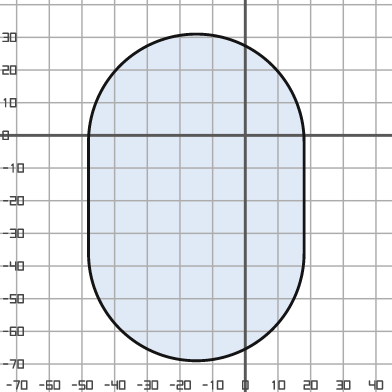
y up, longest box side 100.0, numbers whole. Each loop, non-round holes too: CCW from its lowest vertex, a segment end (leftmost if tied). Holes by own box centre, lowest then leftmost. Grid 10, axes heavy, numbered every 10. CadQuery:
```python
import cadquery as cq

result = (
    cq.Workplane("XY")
    .moveTo(-48.0, -36.0)
    .threePointArc((-15.0, -69.0), (18.0, -36.0))
    .lineTo(18.0, -2.0)
    .threePointArc((-15.0, 31.0), (-48.0, -2.0))
    .close()
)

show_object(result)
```